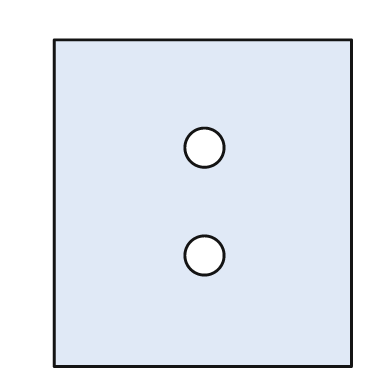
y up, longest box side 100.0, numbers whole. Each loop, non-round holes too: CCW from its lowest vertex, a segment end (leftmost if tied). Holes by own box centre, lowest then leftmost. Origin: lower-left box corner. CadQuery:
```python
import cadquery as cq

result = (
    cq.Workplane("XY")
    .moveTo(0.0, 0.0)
    .lineTo(91.0, 0.0)
    .lineTo(91.0, 100.0)
    .lineTo(0.0, 100.0)
    .close()
    .moveTo(46.0, 34.0)
    .circle(6.0)
    .moveTo(46.0, 67.0)
    .circle(6.0)
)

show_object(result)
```